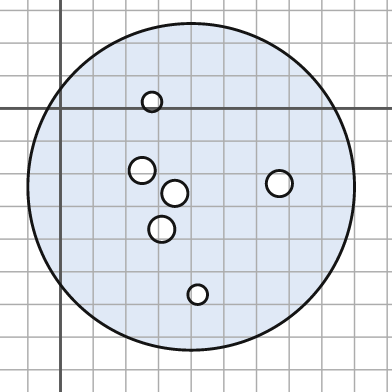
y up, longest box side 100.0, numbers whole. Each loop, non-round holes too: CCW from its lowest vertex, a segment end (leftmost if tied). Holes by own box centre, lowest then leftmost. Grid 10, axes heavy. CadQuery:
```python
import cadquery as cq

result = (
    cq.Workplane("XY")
    .moveTo(40.0, -24.0)
    .circle(50.0)
    .moveTo(42.0, -57.0)
    .circle(3.0)
    .moveTo(31.0, -37.0)
    .circle(4.0)
    .moveTo(35.0, -26.0)
    .circle(4.0)
    .moveTo(67.0, -23.0)
    .circle(4.0)
    .moveTo(25.0, -19.0)
    .circle(4.0)
    .moveTo(28.0, 2.0)
    .circle(3.0)
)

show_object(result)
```